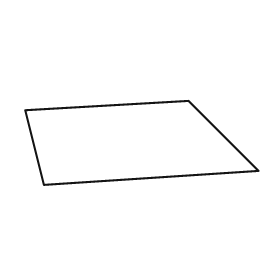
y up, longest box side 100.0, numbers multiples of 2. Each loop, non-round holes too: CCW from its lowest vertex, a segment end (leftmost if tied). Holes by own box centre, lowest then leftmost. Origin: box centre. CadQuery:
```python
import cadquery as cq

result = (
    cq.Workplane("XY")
    .moveTo(-42.0, -18.0)
    .lineTo(50.0, -12.0)
    .lineTo(20.0, 18.0)
    .lineTo(-50.0, 14.0)
    .close()
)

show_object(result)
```